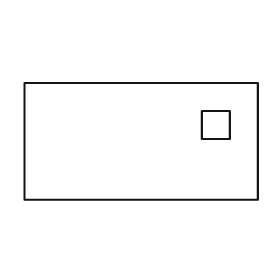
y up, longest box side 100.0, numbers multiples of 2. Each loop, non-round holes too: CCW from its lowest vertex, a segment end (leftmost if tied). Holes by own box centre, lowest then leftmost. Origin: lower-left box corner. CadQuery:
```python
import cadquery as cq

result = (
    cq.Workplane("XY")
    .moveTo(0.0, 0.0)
    .lineTo(100.0, 0.0)
    .lineTo(100.0, 50.0)
    .lineTo(0.0, 50.0)
    .close()
    .moveTo(76.0, 26.0)
    .lineTo(88.0, 26.0)
    .lineTo(88.0, 38.0)
    .lineTo(76.0, 38.0)
    .close()
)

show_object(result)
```